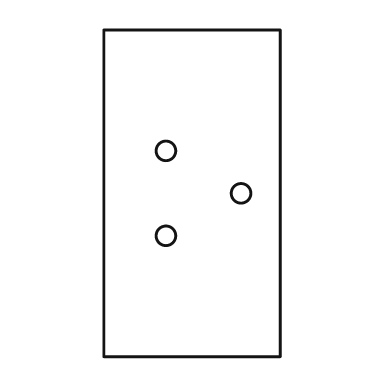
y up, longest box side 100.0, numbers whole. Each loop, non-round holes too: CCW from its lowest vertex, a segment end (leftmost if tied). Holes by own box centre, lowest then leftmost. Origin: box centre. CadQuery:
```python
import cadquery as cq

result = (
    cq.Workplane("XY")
    .moveTo(-27.0, -50.0)
    .lineTo(27.0, -50.0)
    .lineTo(27.0, 50.0)
    .lineTo(-27.0, 50.0)
    .close()
    .moveTo(-8.0, -13.0)
    .circle(3.0)
    .moveTo(15.0, 0.0)
    .circle(3.0)
    .moveTo(-8.0, 13.0)
    .circle(3.0)
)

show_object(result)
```